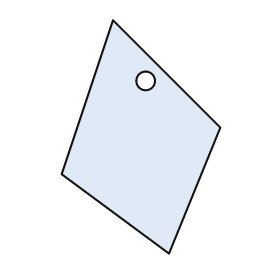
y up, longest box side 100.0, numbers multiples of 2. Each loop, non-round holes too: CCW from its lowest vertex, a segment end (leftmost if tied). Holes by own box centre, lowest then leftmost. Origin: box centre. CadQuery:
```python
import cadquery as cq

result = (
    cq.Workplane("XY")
    .moveTo(12.0, -50.0)
    .lineTo(34.0, 4.0)
    .lineTo(-12.0, 50.0)
    .lineTo(-34.0, -16.0)
    .close()
    .moveTo(2.0, 24.0)
    .circle(4.0)
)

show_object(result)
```